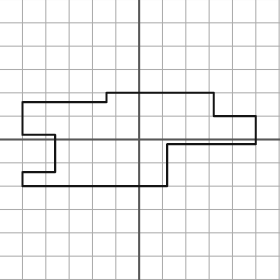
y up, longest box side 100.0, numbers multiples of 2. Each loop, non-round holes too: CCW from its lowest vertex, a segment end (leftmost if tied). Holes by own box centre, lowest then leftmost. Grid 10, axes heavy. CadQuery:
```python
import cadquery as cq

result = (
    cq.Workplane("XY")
    .moveTo(-50.0, -20.0)
    .lineTo(12.0, -20.0)
    .lineTo(12.0, -2.0)
    .lineTo(50.0, -2.0)
    .lineTo(50.0, 10.0)
    .lineTo(32.0, 10.0)
    .lineTo(32.0, 20.0)
    .lineTo(-14.0, 20.0)
    .lineTo(-14.0, 16.0)
    .lineTo(-50.0, 16.0)
    .lineTo(-50.0, 2.0)
    .lineTo(-36.0, 2.0)
    .lineTo(-36.0, -14.0)
    .lineTo(-50.0, -14.0)
    .close()
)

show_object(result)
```